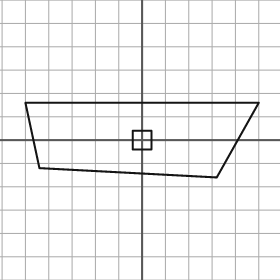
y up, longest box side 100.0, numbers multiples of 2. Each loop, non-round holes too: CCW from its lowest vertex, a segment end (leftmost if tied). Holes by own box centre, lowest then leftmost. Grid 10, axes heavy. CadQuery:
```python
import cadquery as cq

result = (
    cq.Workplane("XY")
    .moveTo(32.0, -16.0)
    .lineTo(50.0, 16.0)
    .lineTo(-50.0, 16.0)
    .lineTo(-44.0, -12.0)
    .close()
    .moveTo(-4.0, -4.0)
    .lineTo(4.0, -4.0)
    .lineTo(4.0, 4.0)
    .lineTo(-4.0, 4.0)
    .close()
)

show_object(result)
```